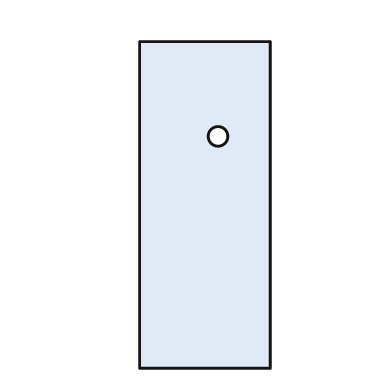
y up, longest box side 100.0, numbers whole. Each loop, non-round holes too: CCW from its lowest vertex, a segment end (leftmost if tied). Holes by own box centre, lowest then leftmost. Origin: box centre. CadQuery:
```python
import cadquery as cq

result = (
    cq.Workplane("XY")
    .moveTo(-20.0, -50.0)
    .lineTo(20.0, -50.0)
    .lineTo(20.0, 50.0)
    .lineTo(-20.0, 50.0)
    .close()
    .moveTo(4.0, 21.0)
    .circle(3.0)
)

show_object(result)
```